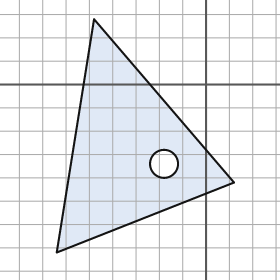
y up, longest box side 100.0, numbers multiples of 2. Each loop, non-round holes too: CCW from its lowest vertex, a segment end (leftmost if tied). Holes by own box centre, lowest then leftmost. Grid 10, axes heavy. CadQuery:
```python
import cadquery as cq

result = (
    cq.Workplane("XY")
    .moveTo(-64.0, -72.0)
    .lineTo(12.0, -42.0)
    .lineTo(-48.0, 28.0)
    .close()
    .moveTo(-18.0, -34.0)
    .circle(6.0)
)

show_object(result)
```